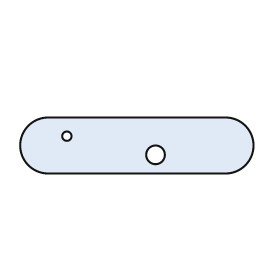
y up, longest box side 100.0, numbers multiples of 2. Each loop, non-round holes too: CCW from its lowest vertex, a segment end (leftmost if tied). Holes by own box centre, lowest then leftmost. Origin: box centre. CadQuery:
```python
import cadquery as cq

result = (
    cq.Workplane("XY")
    .moveTo(-38.0, -12.0)
    .lineTo(38.0, -12.0)
    .threePointArc((50.0, 0.0), (38.0, 12.0))
    .lineTo(-38.0, 12.0)
    .threePointArc((-50.0, 0.0), (-38.0, -12.0))
    .close()
    .moveTo(8.0, -4.0)
    .circle(4.0)
    .moveTo(-30.0, 4.0)
    .circle(2.0)
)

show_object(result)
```